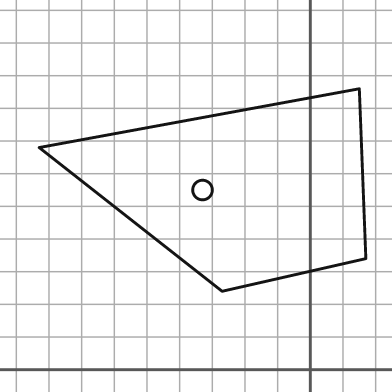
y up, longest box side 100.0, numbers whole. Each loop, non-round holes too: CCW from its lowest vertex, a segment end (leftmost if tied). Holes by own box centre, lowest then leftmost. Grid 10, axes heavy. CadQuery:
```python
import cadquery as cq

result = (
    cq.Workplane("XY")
    .moveTo(-27.0, 24.0)
    .lineTo(17.0, 34.0)
    .lineTo(15.0, 86.0)
    .lineTo(-83.0, 68.0)
    .close()
    .moveTo(-33.0, 55.0)
    .circle(3.0)
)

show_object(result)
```